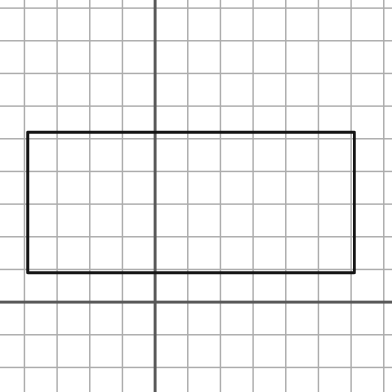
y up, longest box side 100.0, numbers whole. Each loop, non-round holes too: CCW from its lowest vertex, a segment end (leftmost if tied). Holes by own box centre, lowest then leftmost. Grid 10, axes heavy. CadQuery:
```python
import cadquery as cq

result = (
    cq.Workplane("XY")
    .moveTo(-39.0, 9.0)
    .lineTo(61.0, 9.0)
    .lineTo(61.0, 52.0)
    .lineTo(-39.0, 52.0)
    .close()
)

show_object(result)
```